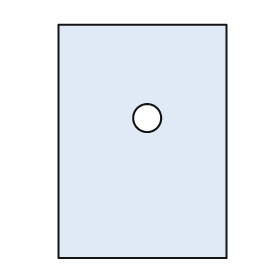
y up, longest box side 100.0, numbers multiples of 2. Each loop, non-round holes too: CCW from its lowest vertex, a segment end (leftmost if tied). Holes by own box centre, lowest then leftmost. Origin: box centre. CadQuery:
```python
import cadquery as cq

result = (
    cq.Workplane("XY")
    .moveTo(-36.0, -50.0)
    .lineTo(36.0, -50.0)
    .lineTo(36.0, 50.0)
    .lineTo(-36.0, 50.0)
    .close()
    .moveTo(2.0, 10.0)
    .circle(6.0)
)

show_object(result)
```